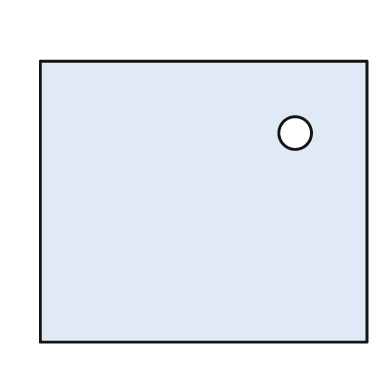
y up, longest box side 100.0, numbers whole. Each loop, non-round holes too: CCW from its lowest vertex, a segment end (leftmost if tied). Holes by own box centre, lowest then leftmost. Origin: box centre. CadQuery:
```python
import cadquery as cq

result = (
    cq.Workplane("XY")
    .moveTo(-50.0, -43.0)
    .lineTo(50.0, -43.0)
    .lineTo(50.0, 43.0)
    .lineTo(-50.0, 43.0)
    .close()
    .moveTo(28.0, 21.0)
    .circle(5.0)
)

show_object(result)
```